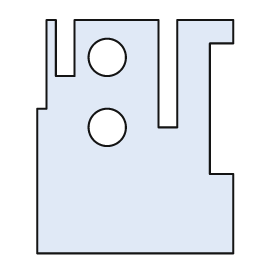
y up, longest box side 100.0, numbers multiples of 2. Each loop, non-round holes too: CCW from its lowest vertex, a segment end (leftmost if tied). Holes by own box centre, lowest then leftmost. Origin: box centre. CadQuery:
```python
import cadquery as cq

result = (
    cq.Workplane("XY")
    .moveTo(-42.0, -50.0)
    .lineTo(42.0, -50.0)
    .lineTo(42.0, -16.0)
    .lineTo(32.0, -16.0)
    .lineTo(32.0, 40.0)
    .lineTo(42.0, 40.0)
    .lineTo(42.0, 50.0)
    .lineTo(18.0, 50.0)
    .lineTo(18.0, 4.0)
    .lineTo(10.0, 4.0)
    .lineTo(10.0, 50.0)
    .lineTo(-26.0, 50.0)
    .lineTo(-26.0, 26.0)
    .lineTo(-34.0, 26.0)
    .lineTo(-34.0, 50.0)
    .lineTo(-38.0, 50.0)
    .lineTo(-38.0, 12.0)
    .lineTo(-42.0, 12.0)
    .close()
    .moveTo(-12.0, 4.0)
    .circle(8.0)
    .moveTo(-12.0, 34.0)
    .circle(8.0)
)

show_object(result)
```